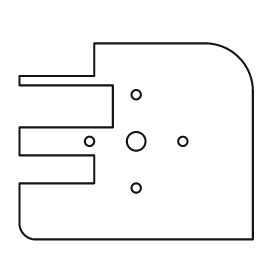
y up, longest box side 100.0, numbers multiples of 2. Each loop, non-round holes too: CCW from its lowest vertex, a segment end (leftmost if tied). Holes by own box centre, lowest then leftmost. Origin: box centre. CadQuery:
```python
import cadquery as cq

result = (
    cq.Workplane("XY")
    .moveTo(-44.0, -42.0)
    .lineTo(50.0, -42.0)
    .lineTo(50.0, 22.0)
    .threePointArc((44.0, 36.0), (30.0, 42.0))
    .lineTo(-18.0, 42.0)
    .lineTo(-18.0, 28.0)
    .lineTo(-50.0, 28.0)
    .lineTo(-50.0, 24.0)
    .lineTo(-10.0, 24.0)
    .lineTo(-10.0, 6.0)
    .lineTo(-50.0, 6.0)
    .lineTo(-50.0, -6.0)
    .lineTo(-18.0, -6.0)
    .lineTo(-18.0, -18.0)
    .lineTo(-50.0, -18.0)
    .lineTo(-50.0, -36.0)
    .threePointArc((-48.0, -40.0), (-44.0, -42.0))
    .close()
    .moveTo(0.0, -20.0)
    .circle(2.0)
    .moveTo(-20.0, 0.0)
    .circle(2.0)
    .moveTo(0.0, 0.0)
    .circle(4.0)
    .moveTo(20.0, 0.0)
    .circle(2.0)
    .moveTo(0.0, 20.0)
    .circle(2.0)
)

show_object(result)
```